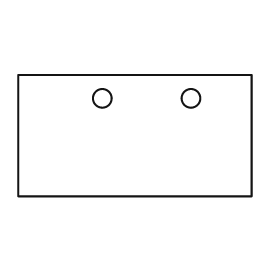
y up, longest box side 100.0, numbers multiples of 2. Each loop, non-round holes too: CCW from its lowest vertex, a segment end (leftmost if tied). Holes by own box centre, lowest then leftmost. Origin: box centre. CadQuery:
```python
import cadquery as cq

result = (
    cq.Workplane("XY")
    .moveTo(-50.0, -26.0)
    .lineTo(50.0, -26.0)
    .lineTo(50.0, 26.0)
    .lineTo(-50.0, 26.0)
    .close()
    .moveTo(-14.0, 16.0)
    .circle(4.0)
    .moveTo(24.0, 16.0)
    .circle(4.0)
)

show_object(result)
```